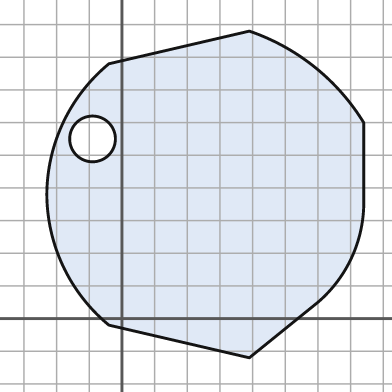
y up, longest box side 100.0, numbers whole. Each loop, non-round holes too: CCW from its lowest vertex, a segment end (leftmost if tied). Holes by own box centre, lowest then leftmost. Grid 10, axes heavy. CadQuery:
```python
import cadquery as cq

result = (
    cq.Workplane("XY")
    .moveTo(39.0, -12.0)
    .lineTo(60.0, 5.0)
    .threePointArc((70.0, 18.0), (74.0, 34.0))
    .lineTo(74.0, 60.0)
    .threePointArc((59.0, 77.0), (39.0, 88.0))
    .lineTo(-4.0, 78.0)
    .threePointArc((-18.0, 60.0), (-23.0, 38.0))
    .threePointArc((-18.0, 16.0), (-4.0, -2.0))
    .close()
    .moveTo(-9.0, 55.0)
    .circle(7.0)
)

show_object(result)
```